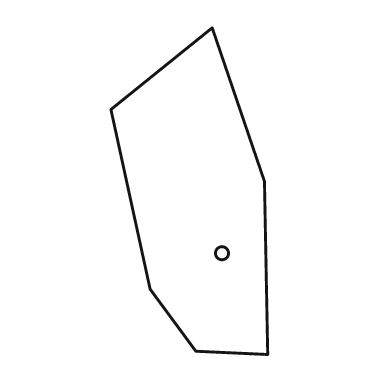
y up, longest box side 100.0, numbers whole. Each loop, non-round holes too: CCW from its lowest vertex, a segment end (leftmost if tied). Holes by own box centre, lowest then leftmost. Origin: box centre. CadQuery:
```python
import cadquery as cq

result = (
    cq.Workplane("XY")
    .moveTo(24.0, -50.0)
    .lineTo(23.0, 3.0)
    .lineTo(7.0, 50.0)
    .lineTo(-24.0, 25.0)
    .lineTo(-12.0, -30.0)
    .lineTo(2.0, -49.0)
    .close()
    .moveTo(10.0, -19.0)
    .circle(2.0)
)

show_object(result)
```